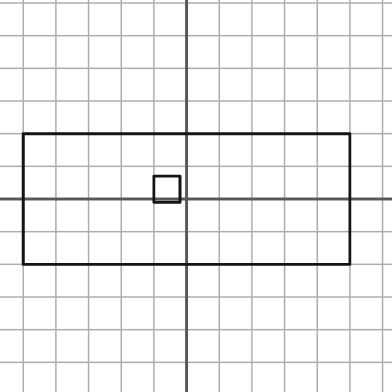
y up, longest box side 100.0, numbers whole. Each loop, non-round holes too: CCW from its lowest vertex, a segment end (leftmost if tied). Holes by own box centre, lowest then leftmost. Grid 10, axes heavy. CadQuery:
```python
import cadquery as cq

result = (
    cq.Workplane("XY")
    .moveTo(-50.0, -20.0)
    .lineTo(50.0, -20.0)
    .lineTo(50.0, 20.0)
    .lineTo(-50.0, 20.0)
    .close()
    .moveTo(-10.0, -1.0)
    .lineTo(-2.0, -1.0)
    .lineTo(-2.0, 7.0)
    .lineTo(-10.0, 7.0)
    .close()
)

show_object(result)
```